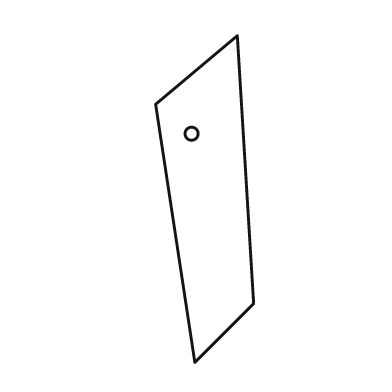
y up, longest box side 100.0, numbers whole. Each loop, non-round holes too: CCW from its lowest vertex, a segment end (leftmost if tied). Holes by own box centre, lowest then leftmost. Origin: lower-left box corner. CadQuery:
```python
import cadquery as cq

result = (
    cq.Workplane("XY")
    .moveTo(12.0, 0.0)
    .lineTo(30.0, 18.0)
    .lineTo(25.0, 100.0)
    .lineTo(0.0, 79.0)
    .close()
    .moveTo(11.0, 70.0)
    .circle(2.0)
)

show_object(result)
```